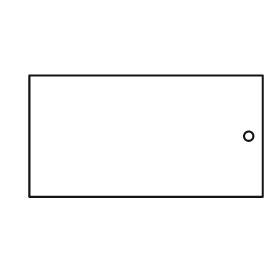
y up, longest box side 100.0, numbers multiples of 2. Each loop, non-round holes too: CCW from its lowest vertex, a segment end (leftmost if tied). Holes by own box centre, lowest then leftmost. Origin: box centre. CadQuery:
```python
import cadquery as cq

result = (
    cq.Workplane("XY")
    .moveTo(-50.0, -26.0)
    .lineTo(50.0, -26.0)
    .lineTo(50.0, 26.0)
    .lineTo(-50.0, 26.0)
    .close()
    .moveTo(44.0, 0.0)
    .circle(2.0)
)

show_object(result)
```